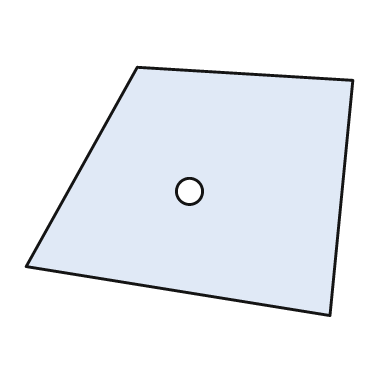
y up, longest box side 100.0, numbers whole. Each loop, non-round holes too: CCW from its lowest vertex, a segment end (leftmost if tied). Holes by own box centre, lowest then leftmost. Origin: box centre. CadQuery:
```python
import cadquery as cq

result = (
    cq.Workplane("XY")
    .moveTo(43.0, -38.0)
    .lineTo(50.0, 34.0)
    .lineTo(-16.0, 38.0)
    .lineTo(-50.0, -23.0)
    .close()
    .moveTo(0.0, 0.0)
    .circle(4.0)
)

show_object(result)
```